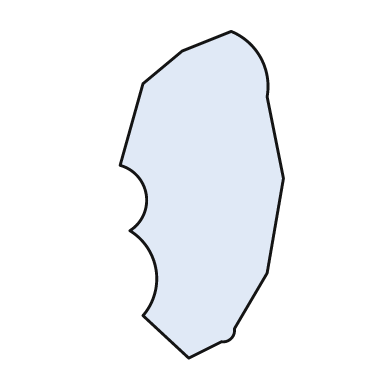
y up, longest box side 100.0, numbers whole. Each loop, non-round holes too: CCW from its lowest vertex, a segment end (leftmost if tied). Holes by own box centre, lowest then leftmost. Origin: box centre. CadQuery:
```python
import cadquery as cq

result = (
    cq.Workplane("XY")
    .moveTo(-4.0, -50.0)
    .lineTo(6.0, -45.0)
    .threePointArc((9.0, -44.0), (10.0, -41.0))
    .lineTo(20.0, -24.0)
    .lineTo(25.0, 5.0)
    .lineTo(20.0, 30.0)
    .threePointArc((18.0, 42.0), (9.0, 50.0))
    .lineTo(-6.0, 44.0)
    .lineTo(-18.0, 34.0)
    .lineTo(-25.0, 9.0)
    .threePointArc((-17.0, 0.0), (-22.0, -11.0))
    .threePointArc((-14.0, -23.0), (-18.0, -37.0))
    .close()
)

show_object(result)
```